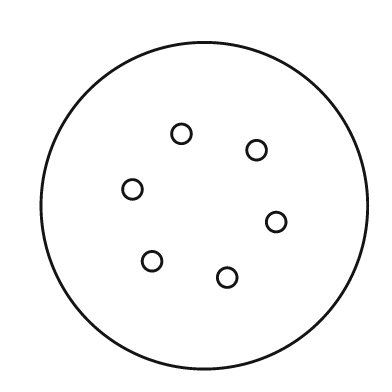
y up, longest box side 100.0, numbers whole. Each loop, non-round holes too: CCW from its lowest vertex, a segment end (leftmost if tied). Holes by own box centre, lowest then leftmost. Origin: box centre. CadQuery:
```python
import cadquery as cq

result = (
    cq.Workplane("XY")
    .moveTo(0.0, 0.0)
    .circle(50.0)
    .moveTo(7.0, -22.0)
    .circle(3.0)
    .moveTo(-16.0, -17.0)
    .circle(3.0)
    .moveTo(22.0, -5.0)
    .circle(3.0)
    .moveTo(-22.0, 5.0)
    .circle(3.0)
    .moveTo(16.0, 17.0)
    .circle(3.0)
    .moveTo(-7.0, 22.0)
    .circle(3.0)
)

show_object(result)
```